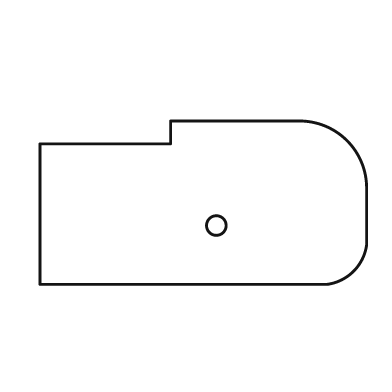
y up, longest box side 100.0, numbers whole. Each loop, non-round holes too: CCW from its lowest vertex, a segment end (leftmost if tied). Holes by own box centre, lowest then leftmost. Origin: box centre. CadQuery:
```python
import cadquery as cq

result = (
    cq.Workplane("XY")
    .moveTo(-50.0, -25.0)
    .lineTo(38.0, -25.0)
    .threePointArc((46.0, -21.0), (50.0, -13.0))
    .lineTo(50.0, 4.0)
    .threePointArc((44.0, 19.0), (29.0, 25.0))
    .lineTo(-10.0, 25.0)
    .lineTo(-10.0, 18.0)
    .lineTo(-50.0, 18.0)
    .close()
    .moveTo(4.0, -7.0)
    .circle(3.0)
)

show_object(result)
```